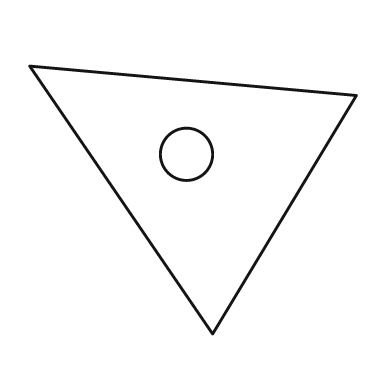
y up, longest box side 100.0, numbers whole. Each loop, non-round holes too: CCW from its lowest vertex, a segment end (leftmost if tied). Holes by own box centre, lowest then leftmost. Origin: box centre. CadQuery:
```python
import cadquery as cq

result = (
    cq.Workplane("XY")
    .moveTo(6.0, -41.0)
    .lineTo(50.0, 32.0)
    .lineTo(-50.0, 41.0)
    .close()
    .moveTo(-2.0, 14.0)
    .circle(8.0)
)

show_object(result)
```